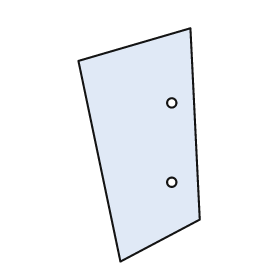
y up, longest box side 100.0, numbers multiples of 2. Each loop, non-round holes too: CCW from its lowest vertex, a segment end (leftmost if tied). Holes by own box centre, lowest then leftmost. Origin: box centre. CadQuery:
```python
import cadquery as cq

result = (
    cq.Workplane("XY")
    .moveTo(-8.0, -50.0)
    .lineTo(26.0, -32.0)
    .lineTo(22.0, 50.0)
    .lineTo(-26.0, 36.0)
    .close()
    .moveTo(14.0, -16.0)
    .circle(2.0)
    .moveTo(14.0, 18.0)
    .circle(2.0)
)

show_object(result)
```